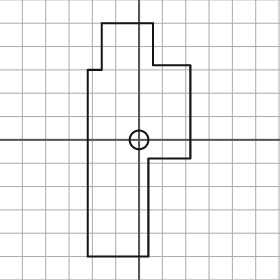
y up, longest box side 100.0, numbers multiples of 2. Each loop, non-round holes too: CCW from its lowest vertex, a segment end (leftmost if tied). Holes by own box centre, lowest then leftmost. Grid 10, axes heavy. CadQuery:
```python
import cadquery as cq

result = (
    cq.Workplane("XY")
    .moveTo(-22.0, -50.0)
    .lineTo(4.0, -50.0)
    .lineTo(4.0, -8.0)
    .lineTo(22.0, -8.0)
    .lineTo(22.0, 32.0)
    .lineTo(6.0, 32.0)
    .lineTo(6.0, 50.0)
    .lineTo(-16.0, 50.0)
    .lineTo(-16.0, 30.0)
    .lineTo(-22.0, 30.0)
    .close()
    .moveTo(0.0, 0.0)
    .circle(4.0)
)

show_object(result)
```